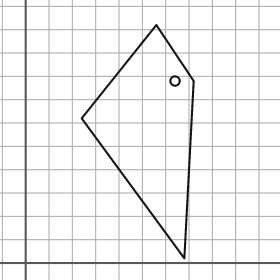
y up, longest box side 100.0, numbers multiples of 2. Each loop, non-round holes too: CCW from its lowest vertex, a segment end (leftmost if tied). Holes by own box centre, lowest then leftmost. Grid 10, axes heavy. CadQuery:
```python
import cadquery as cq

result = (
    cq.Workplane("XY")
    .moveTo(68.0, 2.0)
    .lineTo(72.0, 78.0)
    .lineTo(56.0, 102.0)
    .lineTo(24.0, 62.0)
    .close()
    .moveTo(64.0, 78.0)
    .circle(2.0)
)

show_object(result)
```